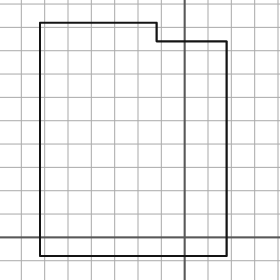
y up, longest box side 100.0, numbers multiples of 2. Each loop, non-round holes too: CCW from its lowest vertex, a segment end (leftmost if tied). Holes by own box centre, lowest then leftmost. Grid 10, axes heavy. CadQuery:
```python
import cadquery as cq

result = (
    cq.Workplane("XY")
    .moveTo(-62.0, -8.0)
    .lineTo(18.0, -8.0)
    .lineTo(18.0, 84.0)
    .lineTo(-12.0, 84.0)
    .lineTo(-12.0, 92.0)
    .lineTo(-62.0, 92.0)
    .close()
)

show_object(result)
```